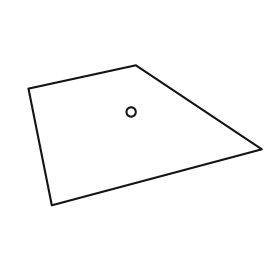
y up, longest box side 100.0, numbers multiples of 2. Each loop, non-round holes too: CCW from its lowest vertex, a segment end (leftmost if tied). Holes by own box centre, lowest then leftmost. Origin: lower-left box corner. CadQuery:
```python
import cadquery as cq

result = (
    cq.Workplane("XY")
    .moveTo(10.0, 0.0)
    .lineTo(100.0, 24.0)
    .lineTo(46.0, 60.0)
    .lineTo(0.0, 50.0)
    .close()
    .moveTo(44.0, 40.0)
    .circle(2.0)
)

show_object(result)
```